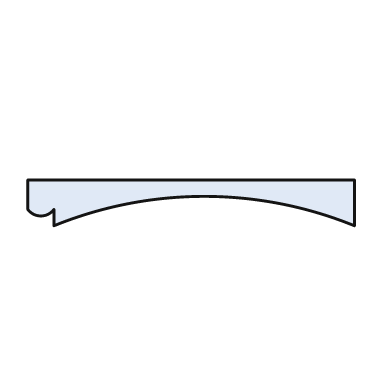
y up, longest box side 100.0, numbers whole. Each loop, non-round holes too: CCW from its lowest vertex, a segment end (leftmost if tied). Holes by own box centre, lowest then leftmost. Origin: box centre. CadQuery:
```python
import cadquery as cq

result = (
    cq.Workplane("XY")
    .moveTo(-42.0, -7.0)
    .threePointArc((4.0, 2.0), (50.0, -7.0))
    .lineTo(50.0, 7.0)
    .lineTo(-50.0, 7.0)
    .lineTo(-50.0, -2.0)
    .threePointArc((-46.0, -4.0), (-42.0, -2.0))
    .close()
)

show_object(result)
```